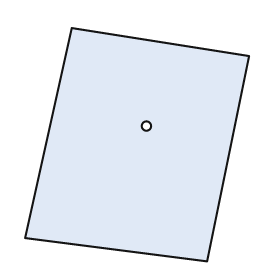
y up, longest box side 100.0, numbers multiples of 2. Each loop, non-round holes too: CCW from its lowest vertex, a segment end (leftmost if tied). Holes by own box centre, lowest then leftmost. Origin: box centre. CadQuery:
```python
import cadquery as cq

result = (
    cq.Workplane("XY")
    .moveTo(30.0, -50.0)
    .lineTo(48.0, 38.0)
    .lineTo(-28.0, 50.0)
    .lineTo(-48.0, -40.0)
    .close()
    .moveTo(4.0, 8.0)
    .circle(2.0)
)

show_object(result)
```